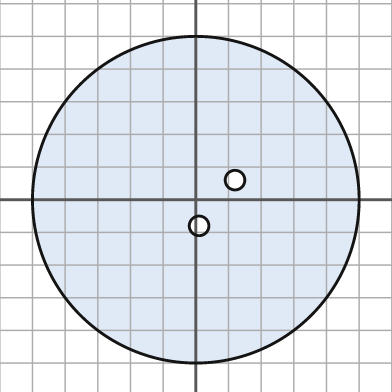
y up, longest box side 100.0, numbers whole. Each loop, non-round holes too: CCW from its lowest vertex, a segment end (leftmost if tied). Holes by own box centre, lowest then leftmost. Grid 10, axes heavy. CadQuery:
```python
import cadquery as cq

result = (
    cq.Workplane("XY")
    .moveTo(0.0, 0.0)
    .circle(50.0)
    .moveTo(1.0, -8.0)
    .circle(3.0)
    .moveTo(12.0, 6.0)
    .circle(3.0)
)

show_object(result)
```